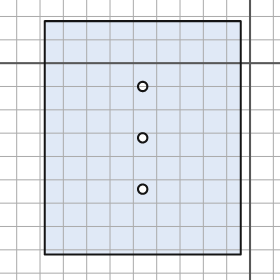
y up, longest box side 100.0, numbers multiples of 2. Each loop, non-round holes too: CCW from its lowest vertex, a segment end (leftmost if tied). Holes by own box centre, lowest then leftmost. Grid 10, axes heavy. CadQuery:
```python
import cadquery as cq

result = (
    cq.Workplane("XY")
    .moveTo(-88.0, -82.0)
    .lineTo(-4.0, -82.0)
    .lineTo(-4.0, 18.0)
    .lineTo(-88.0, 18.0)
    .close()
    .moveTo(-46.0, -54.0)
    .circle(2.0)
    .moveTo(-46.0, -32.0)
    .circle(2.0)
    .moveTo(-46.0, -10.0)
    .circle(2.0)
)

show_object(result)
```